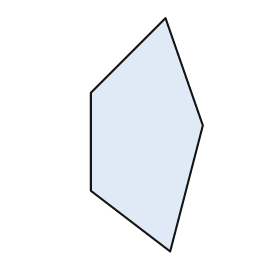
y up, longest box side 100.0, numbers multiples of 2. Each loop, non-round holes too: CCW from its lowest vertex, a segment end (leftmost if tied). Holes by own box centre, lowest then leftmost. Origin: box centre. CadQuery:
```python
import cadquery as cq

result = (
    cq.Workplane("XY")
    .moveTo(10.0, -50.0)
    .lineTo(24.0, 4.0)
    .lineTo(8.0, 50.0)
    .lineTo(-24.0, 18.0)
    .lineTo(-24.0, -24.0)
    .close()
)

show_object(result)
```